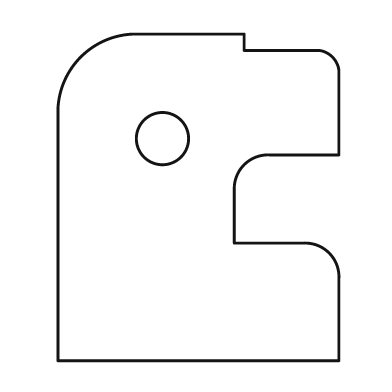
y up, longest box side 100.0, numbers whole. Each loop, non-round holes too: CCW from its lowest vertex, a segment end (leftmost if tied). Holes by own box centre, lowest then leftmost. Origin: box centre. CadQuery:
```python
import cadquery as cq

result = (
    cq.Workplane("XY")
    .moveTo(-43.0, -50.0)
    .lineTo(43.0, -50.0)
    .lineTo(43.0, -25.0)
    .threePointArc((40.0, -17.0), (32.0, -14.0))
    .lineTo(11.0, -14.0)
    .lineTo(11.0, 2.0)
    .threePointArc((14.0, 10.0), (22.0, 13.0))
    .lineTo(43.0, 13.0)
    .lineTo(43.0, 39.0)
    .threePointArc((41.0, 43.0), (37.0, 45.0))
    .lineTo(14.0, 45.0)
    .lineTo(14.0, 50.0)
    .lineTo(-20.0, 50.0)
    .threePointArc((-36.0, 43.0), (-43.0, 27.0))
    .close()
    .moveTo(-11.0, 18.0)
    .circle(8.0)
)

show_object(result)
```